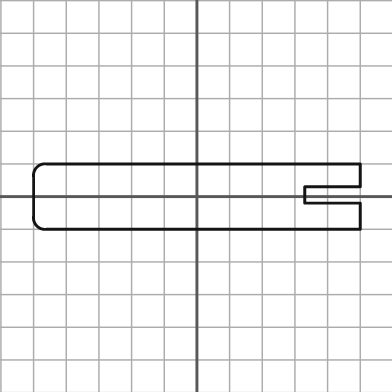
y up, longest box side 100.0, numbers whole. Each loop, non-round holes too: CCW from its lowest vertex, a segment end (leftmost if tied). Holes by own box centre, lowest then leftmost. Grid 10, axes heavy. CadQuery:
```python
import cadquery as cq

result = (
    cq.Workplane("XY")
    .moveTo(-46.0, -10.0)
    .lineTo(50.0, -10.0)
    .lineTo(50.0, -2.0)
    .lineTo(33.0, -2.0)
    .lineTo(33.0, 3.0)
    .lineTo(50.0, 3.0)
    .lineTo(50.0, 10.0)
    .lineTo(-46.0, 10.0)
    .threePointArc((-49.0, 9.0), (-50.0, 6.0))
    .lineTo(-50.0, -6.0)
    .threePointArc((-49.0, -9.0), (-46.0, -10.0))
    .close()
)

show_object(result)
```